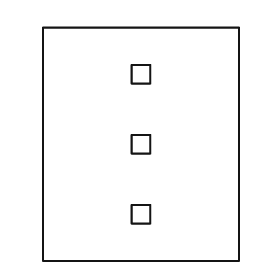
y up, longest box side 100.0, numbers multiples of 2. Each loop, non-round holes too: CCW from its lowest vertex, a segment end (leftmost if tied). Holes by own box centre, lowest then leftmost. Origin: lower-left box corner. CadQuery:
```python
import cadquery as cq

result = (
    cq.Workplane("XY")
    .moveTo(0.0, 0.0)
    .lineTo(84.0, 0.0)
    .lineTo(84.0, 100.0)
    .lineTo(0.0, 100.0)
    .close()
    .moveTo(38.0, 16.0)
    .lineTo(46.0, 16.0)
    .lineTo(46.0, 24.0)
    .lineTo(38.0, 24.0)
    .close()
    .moveTo(38.0, 46.0)
    .lineTo(46.0, 46.0)
    .lineTo(46.0, 54.0)
    .lineTo(38.0, 54.0)
    .close()
    .moveTo(38.0, 76.0)
    .lineTo(46.0, 76.0)
    .lineTo(46.0, 84.0)
    .lineTo(38.0, 84.0)
    .close()
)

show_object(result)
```